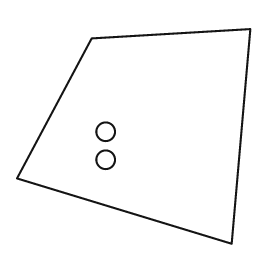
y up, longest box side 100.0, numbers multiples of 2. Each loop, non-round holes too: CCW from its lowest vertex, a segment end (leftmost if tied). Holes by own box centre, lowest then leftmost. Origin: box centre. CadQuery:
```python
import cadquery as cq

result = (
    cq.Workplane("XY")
    .moveTo(42.0, -46.0)
    .lineTo(50.0, 46.0)
    .lineTo(-18.0, 42.0)
    .lineTo(-50.0, -18.0)
    .close()
    .moveTo(-12.0, -10.0)
    .circle(4.0)
    .moveTo(-12.0, 2.0)
    .circle(4.0)
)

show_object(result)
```